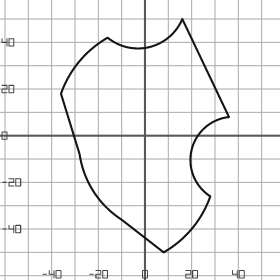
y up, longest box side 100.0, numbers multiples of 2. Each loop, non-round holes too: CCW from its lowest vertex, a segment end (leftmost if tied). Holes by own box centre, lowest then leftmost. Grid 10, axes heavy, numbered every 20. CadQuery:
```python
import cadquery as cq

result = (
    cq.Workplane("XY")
    .moveTo(8.0, -50.0)
    .threePointArc((20.0, -40.0), (28.0, -26.0))
    .threePointArc((20.0, -6.0), (36.0, 8.0))
    .lineTo(16.0, 50.0)
    .threePointArc((2.0, 38.0), (-16.0, 42.0))
    .threePointArc((-28.0, 32.0), (-36.0, 18.0))
    .lineTo(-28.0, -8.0)
    .threePointArc((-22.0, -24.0), (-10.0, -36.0))
    .close()
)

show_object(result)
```